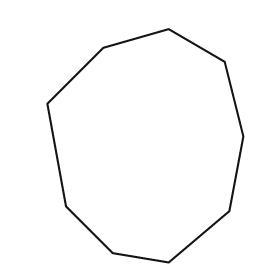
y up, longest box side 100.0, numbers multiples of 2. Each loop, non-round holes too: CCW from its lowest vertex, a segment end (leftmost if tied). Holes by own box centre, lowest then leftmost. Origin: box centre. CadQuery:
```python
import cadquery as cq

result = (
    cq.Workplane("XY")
    .moveTo(10.0, -50.0)
    .lineTo(36.0, -28.0)
    .lineTo(42.0, 4.0)
    .lineTo(34.0, 36.0)
    .lineTo(10.0, 50.0)
    .lineTo(-18.0, 42.0)
    .lineTo(-42.0, 18.0)
    .lineTo(-34.0, -26.0)
    .lineTo(-14.0, -46.0)
    .close()
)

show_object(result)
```